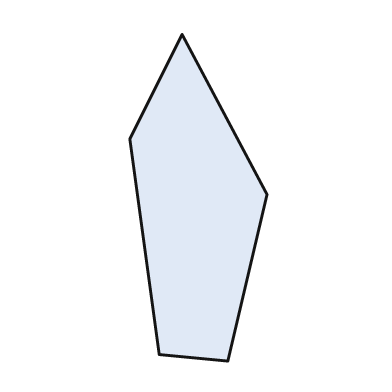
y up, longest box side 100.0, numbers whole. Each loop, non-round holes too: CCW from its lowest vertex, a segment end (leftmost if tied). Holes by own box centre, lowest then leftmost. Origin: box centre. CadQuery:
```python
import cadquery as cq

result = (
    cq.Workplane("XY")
    .moveTo(9.0, -50.0)
    .lineTo(21.0, 1.0)
    .lineTo(-5.0, 50.0)
    .lineTo(-21.0, 18.0)
    .lineTo(-12.0, -48.0)
    .close()
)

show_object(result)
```